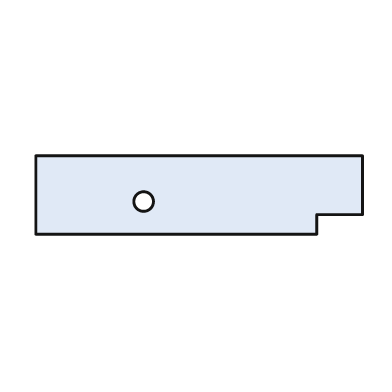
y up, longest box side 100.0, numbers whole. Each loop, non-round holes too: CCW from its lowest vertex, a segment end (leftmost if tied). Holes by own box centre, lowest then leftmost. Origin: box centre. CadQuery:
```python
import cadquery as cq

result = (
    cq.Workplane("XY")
    .moveTo(-50.0, -12.0)
    .lineTo(36.0, -12.0)
    .lineTo(36.0, -6.0)
    .lineTo(50.0, -6.0)
    .lineTo(50.0, 12.0)
    .lineTo(-50.0, 12.0)
    .close()
    .moveTo(-17.0, -2.0)
    .circle(3.0)
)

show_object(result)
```